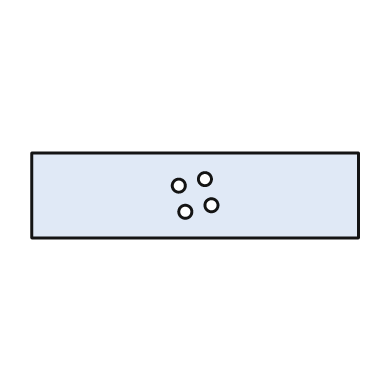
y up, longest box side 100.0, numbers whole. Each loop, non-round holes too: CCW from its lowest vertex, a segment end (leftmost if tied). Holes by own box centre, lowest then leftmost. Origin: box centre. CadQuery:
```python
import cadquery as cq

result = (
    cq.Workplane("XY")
    .moveTo(-50.0, -13.0)
    .lineTo(50.0, -13.0)
    .lineTo(50.0, 13.0)
    .lineTo(-50.0, 13.0)
    .close()
    .moveTo(-3.0, -5.0)
    .circle(2.0)
    .moveTo(5.0, -3.0)
    .circle(2.0)
    .moveTo(-5.0, 3.0)
    .circle(2.0)
    .moveTo(3.0, 5.0)
    .circle(2.0)
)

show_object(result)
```